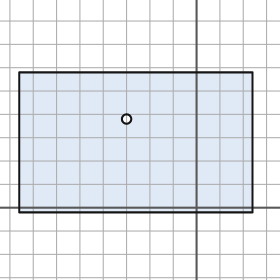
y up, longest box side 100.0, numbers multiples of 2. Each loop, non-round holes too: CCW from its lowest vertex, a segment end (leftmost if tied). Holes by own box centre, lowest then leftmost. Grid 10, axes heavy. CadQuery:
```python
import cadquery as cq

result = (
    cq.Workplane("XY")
    .moveTo(-76.0, -2.0)
    .lineTo(24.0, -2.0)
    .lineTo(24.0, 58.0)
    .lineTo(-76.0, 58.0)
    .close()
    .moveTo(-30.0, 38.0)
    .circle(2.0)
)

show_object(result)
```